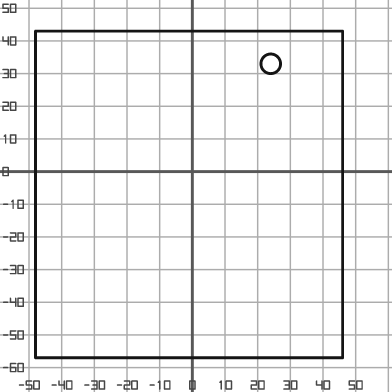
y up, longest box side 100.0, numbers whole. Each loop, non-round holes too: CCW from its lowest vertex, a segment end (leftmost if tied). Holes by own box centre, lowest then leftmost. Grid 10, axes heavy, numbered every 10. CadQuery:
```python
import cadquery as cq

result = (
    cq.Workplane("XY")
    .moveTo(-48.0, -57.0)
    .lineTo(46.0, -57.0)
    .lineTo(46.0, 43.0)
    .lineTo(-48.0, 43.0)
    .close()
    .moveTo(24.0, 33.0)
    .circle(3.0)
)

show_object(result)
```